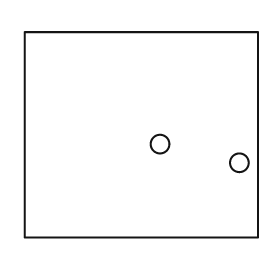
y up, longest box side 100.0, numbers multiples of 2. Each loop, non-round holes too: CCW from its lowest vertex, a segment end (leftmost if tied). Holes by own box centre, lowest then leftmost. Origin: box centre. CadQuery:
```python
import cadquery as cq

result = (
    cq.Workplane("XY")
    .moveTo(-50.0, -44.0)
    .lineTo(50.0, -44.0)
    .lineTo(50.0, 44.0)
    .lineTo(-50.0, 44.0)
    .close()
    .moveTo(42.0, -12.0)
    .circle(4.0)
    .moveTo(8.0, -4.0)
    .circle(4.0)
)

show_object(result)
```